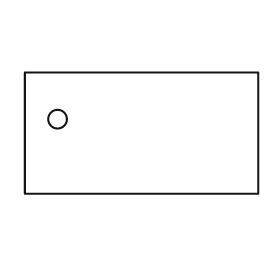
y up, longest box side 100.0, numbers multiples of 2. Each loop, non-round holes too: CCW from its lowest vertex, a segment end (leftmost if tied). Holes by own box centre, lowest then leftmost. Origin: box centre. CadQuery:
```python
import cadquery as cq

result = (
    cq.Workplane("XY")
    .moveTo(-50.0, -26.0)
    .lineTo(50.0, -26.0)
    .lineTo(50.0, 26.0)
    .lineTo(-50.0, 26.0)
    .close()
    .moveTo(-36.0, 6.0)
    .circle(4.0)
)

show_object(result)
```